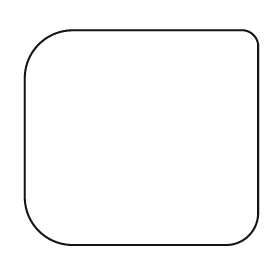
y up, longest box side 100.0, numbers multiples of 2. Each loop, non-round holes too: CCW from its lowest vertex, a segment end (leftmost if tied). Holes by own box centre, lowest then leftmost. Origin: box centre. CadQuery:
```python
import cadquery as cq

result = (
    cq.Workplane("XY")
    .moveTo(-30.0, -46.0)
    .lineTo(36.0, -46.0)
    .threePointArc((46.0, -42.0), (50.0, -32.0))
    .lineTo(50.0, 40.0)
    .threePointArc((48.0, 44.0), (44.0, 46.0))
    .lineTo(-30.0, 46.0)
    .threePointArc((-44.0, 40.0), (-50.0, 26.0))
    .lineTo(-50.0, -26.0)
    .threePointArc((-44.0, -40.0), (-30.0, -46.0))
    .close()
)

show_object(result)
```